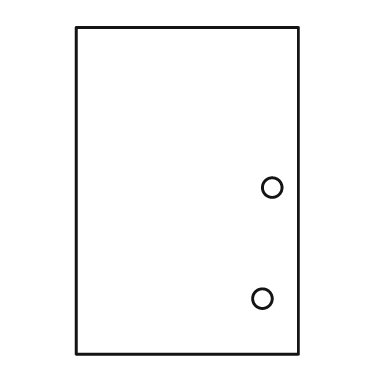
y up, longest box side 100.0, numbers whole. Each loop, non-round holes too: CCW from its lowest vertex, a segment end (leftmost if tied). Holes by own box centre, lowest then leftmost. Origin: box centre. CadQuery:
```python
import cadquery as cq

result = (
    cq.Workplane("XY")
    .moveTo(-34.0, -50.0)
    .lineTo(34.0, -50.0)
    .lineTo(34.0, 50.0)
    .lineTo(-34.0, 50.0)
    .close()
    .moveTo(23.0, -33.0)
    .circle(3.0)
    .moveTo(26.0, 1.0)
    .circle(3.0)
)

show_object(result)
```